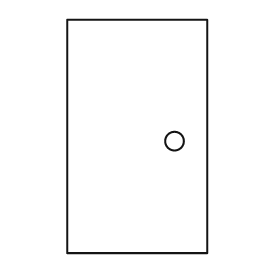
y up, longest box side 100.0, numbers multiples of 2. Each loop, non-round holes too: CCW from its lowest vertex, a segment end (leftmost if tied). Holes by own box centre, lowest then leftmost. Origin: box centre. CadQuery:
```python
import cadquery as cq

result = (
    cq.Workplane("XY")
    .moveTo(-30.0, -50.0)
    .lineTo(30.0, -50.0)
    .lineTo(30.0, 50.0)
    .lineTo(-30.0, 50.0)
    .close()
    .moveTo(16.0, -2.0)
    .circle(4.0)
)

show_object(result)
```